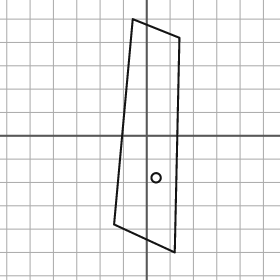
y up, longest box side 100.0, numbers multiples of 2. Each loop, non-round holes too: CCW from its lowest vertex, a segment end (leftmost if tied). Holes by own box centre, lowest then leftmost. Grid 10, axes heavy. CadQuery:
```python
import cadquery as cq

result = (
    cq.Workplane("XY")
    .moveTo(12.0, -50.0)
    .lineTo(14.0, 42.0)
    .lineTo(-6.0, 50.0)
    .lineTo(-14.0, -38.0)
    .close()
    .moveTo(4.0, -18.0)
    .circle(2.0)
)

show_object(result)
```